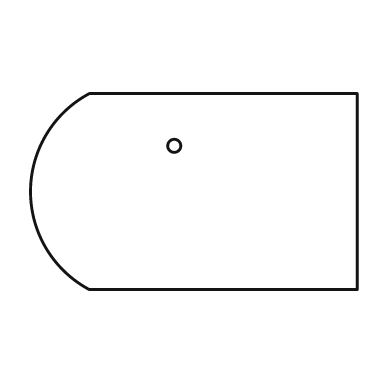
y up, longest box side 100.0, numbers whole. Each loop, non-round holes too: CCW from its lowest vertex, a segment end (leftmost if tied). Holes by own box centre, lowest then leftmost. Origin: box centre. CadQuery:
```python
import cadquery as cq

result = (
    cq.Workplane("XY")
    .moveTo(-32.0, -30.0)
    .lineTo(50.0, -30.0)
    .lineTo(50.0, 30.0)
    .lineTo(-32.0, 30.0)
    .threePointArc((-50.0, 0.0), (-32.0, -30.0))
    .close()
    .moveTo(-6.0, 14.0)
    .circle(2.0)
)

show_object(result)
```